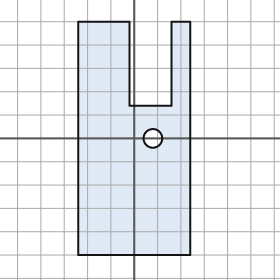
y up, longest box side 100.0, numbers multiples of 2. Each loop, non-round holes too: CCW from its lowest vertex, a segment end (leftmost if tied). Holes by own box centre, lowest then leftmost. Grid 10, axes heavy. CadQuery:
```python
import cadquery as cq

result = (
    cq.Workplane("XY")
    .moveTo(-24.0, -50.0)
    .lineTo(24.0, -50.0)
    .lineTo(24.0, 50.0)
    .lineTo(16.0, 50.0)
    .lineTo(16.0, 14.0)
    .lineTo(-2.0, 14.0)
    .lineTo(-2.0, 50.0)
    .lineTo(-24.0, 50.0)
    .close()
    .moveTo(8.0, 0.0)
    .circle(4.0)
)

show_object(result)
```